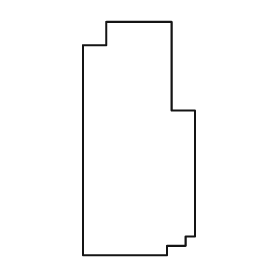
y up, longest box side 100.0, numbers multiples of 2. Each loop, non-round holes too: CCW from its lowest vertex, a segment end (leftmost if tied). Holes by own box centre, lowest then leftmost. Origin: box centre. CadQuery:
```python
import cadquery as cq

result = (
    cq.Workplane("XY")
    .moveTo(-24.0, -50.0)
    .lineTo(12.0, -50.0)
    .lineTo(12.0, -46.0)
    .lineTo(20.0, -46.0)
    .lineTo(20.0, -42.0)
    .lineTo(24.0, -42.0)
    .lineTo(24.0, 12.0)
    .lineTo(14.0, 12.0)
    .lineTo(14.0, 50.0)
    .lineTo(-14.0, 50.0)
    .lineTo(-14.0, 40.0)
    .lineTo(-24.0, 40.0)
    .close()
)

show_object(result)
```